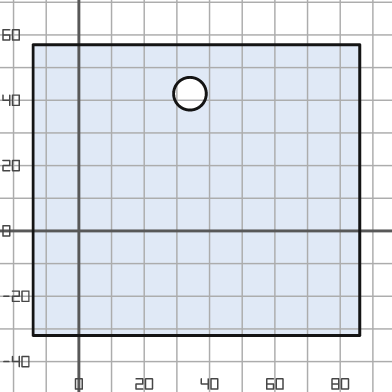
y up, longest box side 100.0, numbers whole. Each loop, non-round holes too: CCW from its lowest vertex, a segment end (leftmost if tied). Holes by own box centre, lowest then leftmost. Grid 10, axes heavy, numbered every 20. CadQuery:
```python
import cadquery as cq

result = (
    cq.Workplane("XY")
    .moveTo(-14.0, -32.0)
    .lineTo(86.0, -32.0)
    .lineTo(86.0, 57.0)
    .lineTo(-14.0, 57.0)
    .close()
    .moveTo(34.0, 42.0)
    .circle(5.0)
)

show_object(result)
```